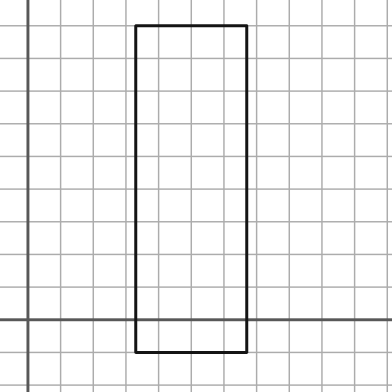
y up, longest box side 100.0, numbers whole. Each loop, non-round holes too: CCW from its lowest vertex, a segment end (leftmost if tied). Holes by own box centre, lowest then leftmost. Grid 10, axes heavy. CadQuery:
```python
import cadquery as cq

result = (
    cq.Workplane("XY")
    .moveTo(33.0, -10.0)
    .lineTo(67.0, -10.0)
    .lineTo(67.0, 90.0)
    .lineTo(33.0, 90.0)
    .close()
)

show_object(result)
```